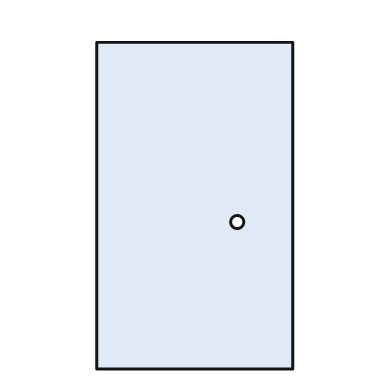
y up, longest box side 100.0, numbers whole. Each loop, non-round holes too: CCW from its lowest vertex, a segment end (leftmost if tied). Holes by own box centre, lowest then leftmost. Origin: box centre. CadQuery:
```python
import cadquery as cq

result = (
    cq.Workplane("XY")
    .moveTo(-30.0, -50.0)
    .lineTo(30.0, -50.0)
    .lineTo(30.0, 50.0)
    .lineTo(-30.0, 50.0)
    .close()
    .moveTo(13.0, -5.0)
    .circle(2.0)
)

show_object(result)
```